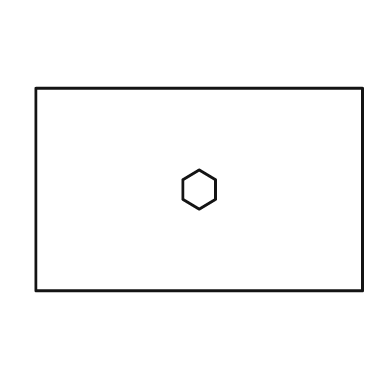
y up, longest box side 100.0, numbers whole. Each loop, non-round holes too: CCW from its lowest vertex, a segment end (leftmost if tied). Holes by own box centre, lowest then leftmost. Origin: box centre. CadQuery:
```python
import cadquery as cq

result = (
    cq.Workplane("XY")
    .moveTo(-50.0, -31.0)
    .lineTo(50.0, -31.0)
    .lineTo(50.0, 31.0)
    .lineTo(-50.0, 31.0)
    .close()
    .moveTo(0.0, -6.0)
    .lineTo(5.0, -3.0)
    .lineTo(5.0, 3.0)
    .lineTo(0.0, 6.0)
    .lineTo(-5.0, 3.0)
    .lineTo(-5.0, -3.0)
    .close()
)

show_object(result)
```